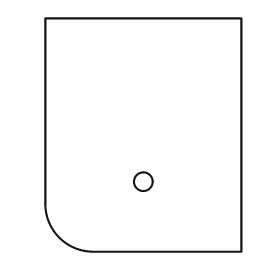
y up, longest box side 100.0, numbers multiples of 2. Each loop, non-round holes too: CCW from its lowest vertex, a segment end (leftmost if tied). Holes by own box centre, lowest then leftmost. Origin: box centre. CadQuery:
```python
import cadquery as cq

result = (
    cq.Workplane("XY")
    .moveTo(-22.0, -50.0)
    .lineTo(42.0, -50.0)
    .lineTo(42.0, 50.0)
    .lineTo(-42.0, 50.0)
    .lineTo(-42.0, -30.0)
    .threePointArc((-36.0, -44.0), (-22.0, -50.0))
    .close()
    .moveTo(0.0, -20.0)
    .circle(4.0)
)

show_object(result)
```